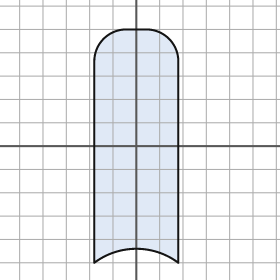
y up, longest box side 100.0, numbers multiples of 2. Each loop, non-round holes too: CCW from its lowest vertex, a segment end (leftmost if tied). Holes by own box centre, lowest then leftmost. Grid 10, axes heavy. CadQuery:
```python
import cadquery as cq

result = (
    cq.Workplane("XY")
    .moveTo(-18.0, -50.0)
    .threePointArc((0.0, -44.0), (18.0, -50.0))
    .lineTo(18.0, 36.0)
    .threePointArc((14.0, 46.0), (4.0, 50.0))
    .lineTo(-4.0, 50.0)
    .threePointArc((-14.0, 46.0), (-18.0, 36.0))
    .close()
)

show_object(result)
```